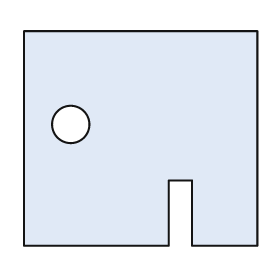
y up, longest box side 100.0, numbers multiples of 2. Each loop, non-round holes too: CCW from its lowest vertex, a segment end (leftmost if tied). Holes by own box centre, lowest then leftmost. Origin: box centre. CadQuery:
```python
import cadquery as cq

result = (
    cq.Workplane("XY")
    .moveTo(-50.0, -46.0)
    .lineTo(12.0, -46.0)
    .lineTo(12.0, -18.0)
    .lineTo(22.0, -18.0)
    .lineTo(22.0, -46.0)
    .lineTo(50.0, -46.0)
    .lineTo(50.0, 46.0)
    .lineTo(-50.0, 46.0)
    .close()
    .moveTo(-30.0, 6.0)
    .circle(8.0)
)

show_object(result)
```